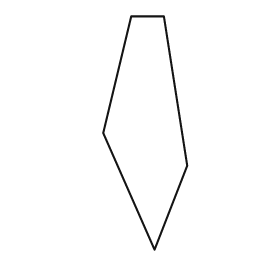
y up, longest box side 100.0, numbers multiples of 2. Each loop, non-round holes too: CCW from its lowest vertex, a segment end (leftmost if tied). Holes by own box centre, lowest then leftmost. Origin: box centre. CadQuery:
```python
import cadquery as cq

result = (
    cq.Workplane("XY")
    .moveTo(4.0, -50.0)
    .lineTo(18.0, -14.0)
    .lineTo(8.0, 50.0)
    .lineTo(-6.0, 50.0)
    .lineTo(-18.0, 0.0)
    .close()
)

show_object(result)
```